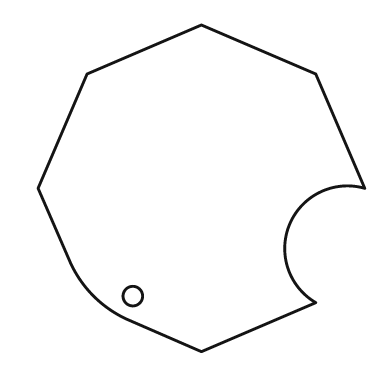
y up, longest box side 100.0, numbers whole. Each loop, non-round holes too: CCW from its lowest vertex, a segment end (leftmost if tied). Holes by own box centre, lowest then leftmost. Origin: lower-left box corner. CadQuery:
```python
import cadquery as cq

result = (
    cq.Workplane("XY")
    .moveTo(50.0, 0.0)
    .lineTo(85.0, 15.0)
    .threePointArc((77.0, 39.0), (100.0, 50.0))
    .lineTo(85.0, 85.0)
    .lineTo(50.0, 100.0)
    .lineTo(15.0, 85.0)
    .lineTo(0.0, 50.0)
    .lineTo(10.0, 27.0)
    .threePointArc((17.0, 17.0), (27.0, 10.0))
    .close()
    .moveTo(29.0, 17.0)
    .circle(3.0)
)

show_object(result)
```